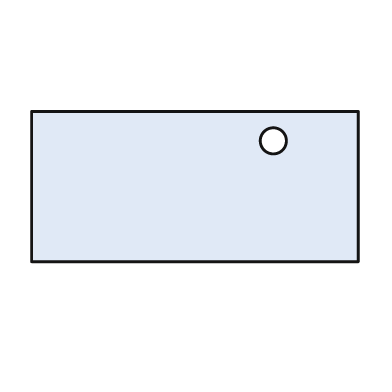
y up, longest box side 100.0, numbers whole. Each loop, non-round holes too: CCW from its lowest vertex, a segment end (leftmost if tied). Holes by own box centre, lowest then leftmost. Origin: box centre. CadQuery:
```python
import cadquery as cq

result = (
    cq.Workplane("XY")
    .moveTo(-50.0, -23.0)
    .lineTo(50.0, -23.0)
    .lineTo(50.0, 23.0)
    .lineTo(-50.0, 23.0)
    .close()
    .moveTo(24.0, 14.0)
    .circle(4.0)
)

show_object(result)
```